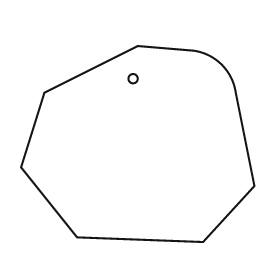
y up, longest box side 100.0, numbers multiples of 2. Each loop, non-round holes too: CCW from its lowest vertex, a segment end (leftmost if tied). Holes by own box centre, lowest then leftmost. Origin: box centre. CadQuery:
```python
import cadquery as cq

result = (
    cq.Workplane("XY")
    .moveTo(28.0, -42.0)
    .lineTo(50.0, -18.0)
    .lineTo(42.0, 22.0)
    .threePointArc((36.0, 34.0), (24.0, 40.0))
    .lineTo(0.0, 42.0)
    .lineTo(-40.0, 22.0)
    .lineTo(-50.0, -10.0)
    .lineTo(-26.0, -40.0)
    .close()
    .moveTo(-2.0, 28.0)
    .circle(2.0)
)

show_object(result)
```